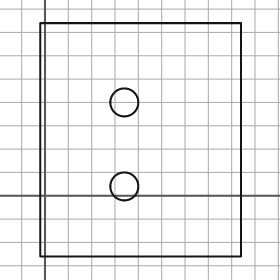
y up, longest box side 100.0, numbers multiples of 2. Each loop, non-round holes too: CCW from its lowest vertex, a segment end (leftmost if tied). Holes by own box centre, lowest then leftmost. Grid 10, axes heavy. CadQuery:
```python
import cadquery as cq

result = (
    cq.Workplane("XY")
    .moveTo(-2.0, -26.0)
    .lineTo(84.0, -26.0)
    .lineTo(84.0, 74.0)
    .lineTo(-2.0, 74.0)
    .close()
    .moveTo(34.0, 4.0)
    .circle(6.0)
    .moveTo(34.0, 40.0)
    .circle(6.0)
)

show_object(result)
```